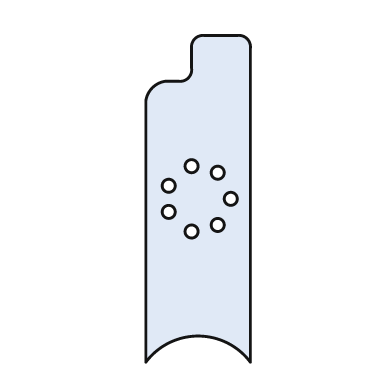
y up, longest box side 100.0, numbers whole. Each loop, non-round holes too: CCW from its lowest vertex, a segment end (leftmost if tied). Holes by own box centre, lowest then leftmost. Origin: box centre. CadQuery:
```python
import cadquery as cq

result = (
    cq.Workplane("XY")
    .moveTo(-16.0, -50.0)
    .threePointArc((0.0, -42.0), (16.0, -50.0))
    .lineTo(16.0, 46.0)
    .threePointArc((15.0, 49.0), (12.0, 50.0))
    .lineTo(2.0, 50.0)
    .threePointArc((-1.0, 49.0), (-2.0, 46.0))
    .lineTo(-2.0, 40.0)
    .threePointArc((-3.0, 37.0), (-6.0, 36.0))
    .lineTo(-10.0, 36.0)
    .threePointArc((-14.0, 34.0), (-16.0, 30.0))
    .close()
    .moveTo(-2.0, -10.0)
    .circle(2.0)
    .moveTo(6.0, -8.0)
    .circle(2.0)
    .moveTo(-9.0, -4.0)
    .circle(2.0)
    .moveTo(10.0, 0.0)
    .circle(2.0)
    .moveTo(-9.0, 4.0)
    .circle(2.0)
    .moveTo(6.0, 8.0)
    .circle(2.0)
    .moveTo(-2.0, 10.0)
    .circle(2.0)
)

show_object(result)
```